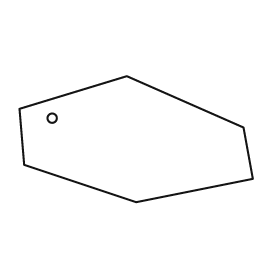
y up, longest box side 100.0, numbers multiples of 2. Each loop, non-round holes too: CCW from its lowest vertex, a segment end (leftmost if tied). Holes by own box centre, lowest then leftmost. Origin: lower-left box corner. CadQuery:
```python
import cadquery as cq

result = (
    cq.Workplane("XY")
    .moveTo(50.0, 0.0)
    .lineTo(100.0, 10.0)
    .lineTo(96.0, 32.0)
    .lineTo(46.0, 54.0)
    .lineTo(0.0, 40.0)
    .lineTo(2.0, 16.0)
    .close()
    .moveTo(14.0, 36.0)
    .circle(2.0)
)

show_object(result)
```